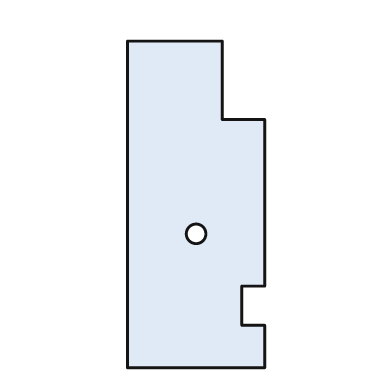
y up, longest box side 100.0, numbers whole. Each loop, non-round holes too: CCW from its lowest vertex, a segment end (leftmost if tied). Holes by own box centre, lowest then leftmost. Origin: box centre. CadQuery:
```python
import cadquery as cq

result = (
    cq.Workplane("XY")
    .moveTo(-21.0, -50.0)
    .lineTo(21.0, -50.0)
    .lineTo(21.0, -37.0)
    .lineTo(14.0, -37.0)
    .lineTo(14.0, -25.0)
    .lineTo(21.0, -25.0)
    .lineTo(21.0, 26.0)
    .lineTo(8.0, 26.0)
    .lineTo(8.0, 50.0)
    .lineTo(-21.0, 50.0)
    .close()
    .moveTo(0.0, -9.0)
    .circle(3.0)
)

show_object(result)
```